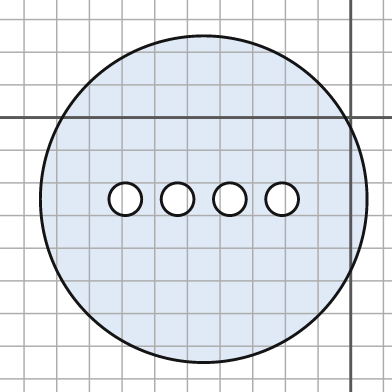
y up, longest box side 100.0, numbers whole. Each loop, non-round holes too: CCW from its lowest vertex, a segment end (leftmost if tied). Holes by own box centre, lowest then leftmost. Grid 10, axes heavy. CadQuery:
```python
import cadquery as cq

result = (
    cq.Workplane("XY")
    .moveTo(-45.0, -25.0)
    .circle(50.0)
    .moveTo(-69.0, -25.0)
    .circle(5.0)
    .moveTo(-53.0, -25.0)
    .circle(5.0)
    .moveTo(-37.0, -25.0)
    .circle(5.0)
    .moveTo(-21.0, -25.0)
    .circle(5.0)
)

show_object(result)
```